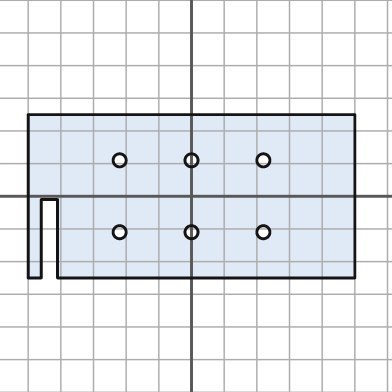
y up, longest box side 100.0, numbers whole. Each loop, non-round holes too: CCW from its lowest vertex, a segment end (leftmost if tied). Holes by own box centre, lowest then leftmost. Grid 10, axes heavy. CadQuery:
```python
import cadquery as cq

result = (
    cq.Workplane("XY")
    .moveTo(-50.0, -25.0)
    .lineTo(-46.0, -25.0)
    .lineTo(-46.0, -1.0)
    .lineTo(-41.0, -1.0)
    .lineTo(-41.0, -25.0)
    .lineTo(50.0, -25.0)
    .lineTo(50.0, 25.0)
    .lineTo(-50.0, 25.0)
    .close()
    .moveTo(-22.0, -11.0)
    .circle(2.0)
    .moveTo(0.0, -11.0)
    .circle(2.0)
    .moveTo(22.0, -11.0)
    .circle(2.0)
    .moveTo(-22.0, 11.0)
    .circle(2.0)
    .moveTo(0.0, 11.0)
    .circle(2.0)
    .moveTo(22.0, 11.0)
    .circle(2.0)
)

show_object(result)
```